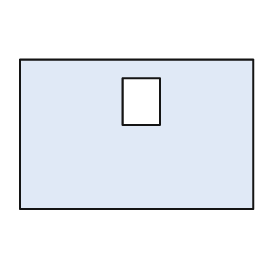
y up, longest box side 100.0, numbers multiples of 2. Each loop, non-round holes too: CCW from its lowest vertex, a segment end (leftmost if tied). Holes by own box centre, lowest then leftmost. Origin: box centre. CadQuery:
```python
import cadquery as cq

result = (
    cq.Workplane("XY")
    .moveTo(-50.0, -32.0)
    .lineTo(50.0, -32.0)
    .lineTo(50.0, 32.0)
    .lineTo(-50.0, 32.0)
    .close()
    .moveTo(-6.0, 4.0)
    .lineTo(10.0, 4.0)
    .lineTo(10.0, 24.0)
    .lineTo(-6.0, 24.0)
    .close()
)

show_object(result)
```